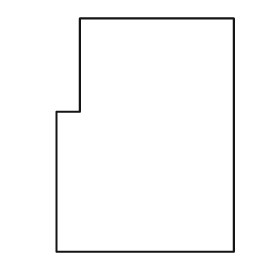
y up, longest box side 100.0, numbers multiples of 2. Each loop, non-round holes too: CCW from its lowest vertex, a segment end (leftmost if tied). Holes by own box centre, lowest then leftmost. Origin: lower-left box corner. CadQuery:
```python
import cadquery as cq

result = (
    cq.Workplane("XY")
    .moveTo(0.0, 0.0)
    .lineTo(76.0, 0.0)
    .lineTo(76.0, 100.0)
    .lineTo(10.0, 100.0)
    .lineTo(10.0, 60.0)
    .lineTo(0.0, 60.0)
    .close()
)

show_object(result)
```